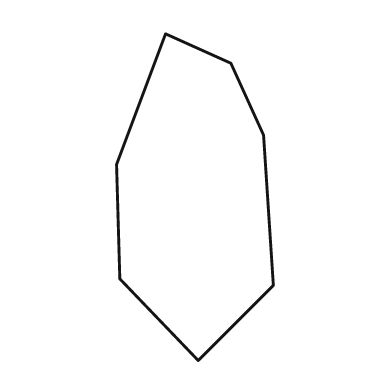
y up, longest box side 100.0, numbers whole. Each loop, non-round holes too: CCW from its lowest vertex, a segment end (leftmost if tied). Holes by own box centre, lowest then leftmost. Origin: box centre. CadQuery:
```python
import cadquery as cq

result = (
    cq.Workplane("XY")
    .moveTo(1.0, -50.0)
    .lineTo(24.0, -27.0)
    .lineTo(21.0, 19.0)
    .lineTo(11.0, 41.0)
    .lineTo(-9.0, 50.0)
    .lineTo(-24.0, 10.0)
    .lineTo(-23.0, -25.0)
    .close()
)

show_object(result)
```